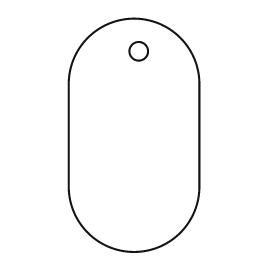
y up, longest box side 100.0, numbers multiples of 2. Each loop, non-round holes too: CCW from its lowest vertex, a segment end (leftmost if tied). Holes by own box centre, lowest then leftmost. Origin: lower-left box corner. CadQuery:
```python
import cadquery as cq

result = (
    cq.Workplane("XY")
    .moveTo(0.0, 28.0)
    .threePointArc((28.0, 0.0), (56.0, 28.0))
    .lineTo(56.0, 72.0)
    .threePointArc((28.0, 100.0), (0.0, 72.0))
    .close()
    .moveTo(30.0, 86.0)
    .circle(4.0)
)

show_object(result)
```